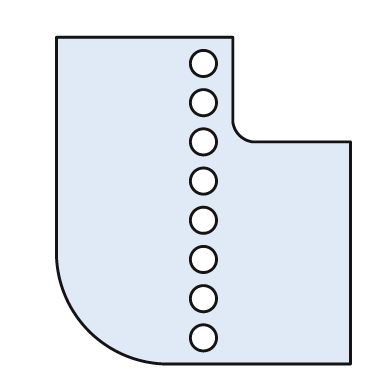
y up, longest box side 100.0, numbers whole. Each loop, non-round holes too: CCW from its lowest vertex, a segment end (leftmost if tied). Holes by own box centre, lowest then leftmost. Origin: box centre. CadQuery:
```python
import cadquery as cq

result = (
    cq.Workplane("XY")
    .moveTo(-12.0, -50.0)
    .lineTo(45.0, -50.0)
    .lineTo(45.0, 18.0)
    .lineTo(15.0, 18.0)
    .threePointArc((11.0, 20.0), (9.0, 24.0))
    .lineTo(9.0, 50.0)
    .lineTo(-45.0, 50.0)
    .lineTo(-45.0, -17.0)
    .threePointArc((-35.0, -40.0), (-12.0, -50.0))
    .close()
    .moveTo(0.0, -42.0)
    .circle(4.0)
    .moveTo(0.0, -30.0)
    .circle(4.0)
    .moveTo(0.0, -18.0)
    .circle(4.0)
    .moveTo(0.0, -6.0)
    .circle(4.0)
    .moveTo(0.0, 6.0)
    .circle(4.0)
    .moveTo(0.0, 18.0)
    .circle(4.0)
    .moveTo(0.0, 30.0)
    .circle(4.0)
    .moveTo(0.0, 42.0)
    .circle(4.0)
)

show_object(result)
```